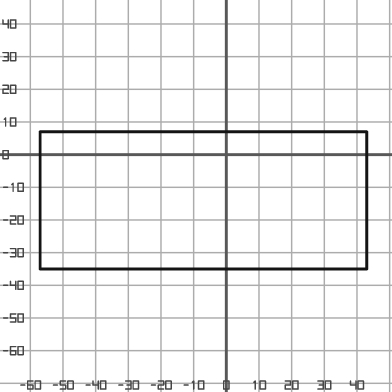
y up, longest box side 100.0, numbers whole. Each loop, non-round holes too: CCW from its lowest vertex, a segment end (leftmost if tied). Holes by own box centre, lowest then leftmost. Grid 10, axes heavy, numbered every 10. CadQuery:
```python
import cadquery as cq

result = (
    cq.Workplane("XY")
    .moveTo(-57.0, -35.0)
    .lineTo(43.0, -35.0)
    .lineTo(43.0, 7.0)
    .lineTo(-57.0, 7.0)
    .close()
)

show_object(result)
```